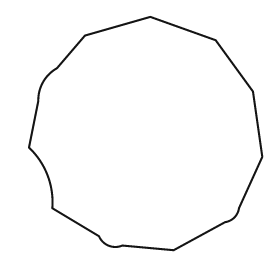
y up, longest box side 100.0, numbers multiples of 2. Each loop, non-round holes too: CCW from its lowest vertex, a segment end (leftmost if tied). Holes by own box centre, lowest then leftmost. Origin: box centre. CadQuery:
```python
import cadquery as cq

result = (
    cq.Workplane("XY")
    .moveTo(12.0, -50.0)
    .lineTo(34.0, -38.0)
    .threePointArc((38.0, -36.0), (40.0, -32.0))
    .lineTo(50.0, -10.0)
    .lineTo(46.0, 18.0)
    .lineTo(30.0, 40.0)
    .lineTo(2.0, 50.0)
    .lineTo(-26.0, 42.0)
    .lineTo(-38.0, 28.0)
    .threePointArc((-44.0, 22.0), (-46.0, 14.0))
    .lineTo(-50.0, -6.0)
    .threePointArc((-42.0, -18.0), (-40.0, -32.0))
    .lineTo(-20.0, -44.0)
    .threePointArc((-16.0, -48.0), (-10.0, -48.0))
    .close()
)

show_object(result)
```